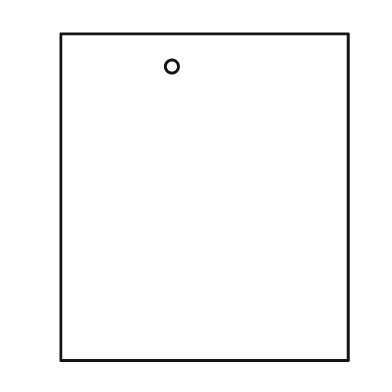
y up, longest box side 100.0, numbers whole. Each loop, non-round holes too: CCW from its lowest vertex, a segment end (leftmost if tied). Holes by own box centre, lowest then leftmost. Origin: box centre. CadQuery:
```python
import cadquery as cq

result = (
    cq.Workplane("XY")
    .moveTo(-44.0, -50.0)
    .lineTo(44.0, -50.0)
    .lineTo(44.0, 50.0)
    .lineTo(-44.0, 50.0)
    .close()
    .moveTo(-10.0, 40.0)
    .circle(2.0)
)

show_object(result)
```